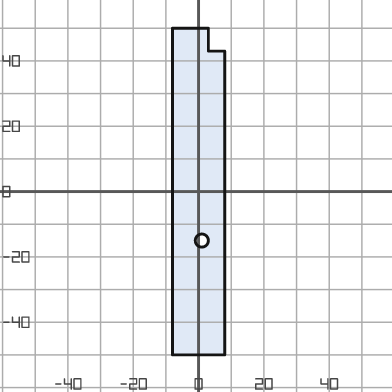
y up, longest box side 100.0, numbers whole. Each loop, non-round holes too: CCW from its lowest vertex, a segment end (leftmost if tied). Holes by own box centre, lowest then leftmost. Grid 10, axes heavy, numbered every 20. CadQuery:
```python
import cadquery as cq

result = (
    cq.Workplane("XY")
    .moveTo(-8.0, -50.0)
    .lineTo(8.0, -50.0)
    .lineTo(8.0, 43.0)
    .lineTo(3.0, 43.0)
    .lineTo(3.0, 50.0)
    .lineTo(-8.0, 50.0)
    .close()
    .moveTo(1.0, -15.0)
    .circle(2.0)
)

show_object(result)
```